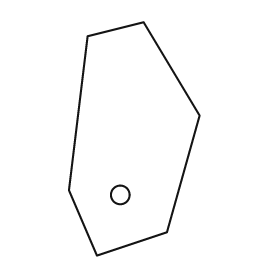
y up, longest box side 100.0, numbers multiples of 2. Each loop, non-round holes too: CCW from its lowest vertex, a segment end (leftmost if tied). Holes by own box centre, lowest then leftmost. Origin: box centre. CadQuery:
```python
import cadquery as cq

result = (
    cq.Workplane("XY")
    .moveTo(-16.0, -50.0)
    .lineTo(14.0, -40.0)
    .lineTo(28.0, 10.0)
    .lineTo(4.0, 50.0)
    .lineTo(-20.0, 44.0)
    .lineTo(-28.0, -22.0)
    .close()
    .moveTo(-6.0, -24.0)
    .circle(4.0)
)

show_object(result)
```